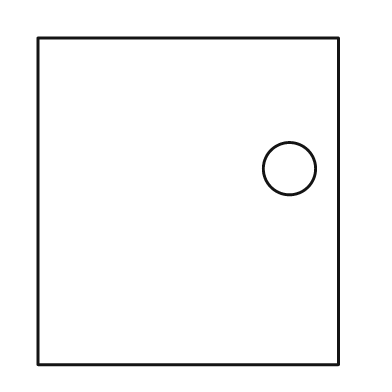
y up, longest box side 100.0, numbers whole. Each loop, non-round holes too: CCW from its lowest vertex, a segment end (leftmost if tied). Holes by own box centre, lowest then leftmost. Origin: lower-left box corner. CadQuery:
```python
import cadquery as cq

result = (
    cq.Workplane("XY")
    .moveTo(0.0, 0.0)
    .lineTo(92.0, 0.0)
    .lineTo(92.0, 100.0)
    .lineTo(0.0, 100.0)
    .close()
    .moveTo(77.0, 60.0)
    .circle(8.0)
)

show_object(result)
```